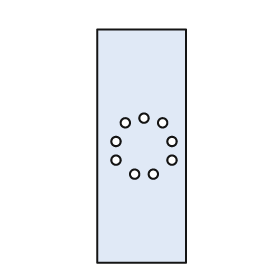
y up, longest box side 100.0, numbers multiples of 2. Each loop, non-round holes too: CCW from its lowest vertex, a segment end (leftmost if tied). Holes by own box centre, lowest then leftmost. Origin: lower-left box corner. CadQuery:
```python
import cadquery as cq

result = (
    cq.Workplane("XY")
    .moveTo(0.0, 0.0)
    .lineTo(38.0, 0.0)
    .lineTo(38.0, 100.0)
    .lineTo(0.0, 100.0)
    .close()
    .moveTo(16.0, 38.0)
    .circle(2.0)
    .moveTo(24.0, 38.0)
    .circle(2.0)
    .moveTo(8.0, 44.0)
    .circle(2.0)
    .moveTo(32.0, 44.0)
    .circle(2.0)
    .moveTo(8.0, 52.0)
    .circle(2.0)
    .moveTo(32.0, 52.0)
    .circle(2.0)
    .moveTo(12.0, 60.0)
    .circle(2.0)
    .moveTo(28.0, 60.0)
    .circle(2.0)
    .moveTo(20.0, 62.0)
    .circle(2.0)
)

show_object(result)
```